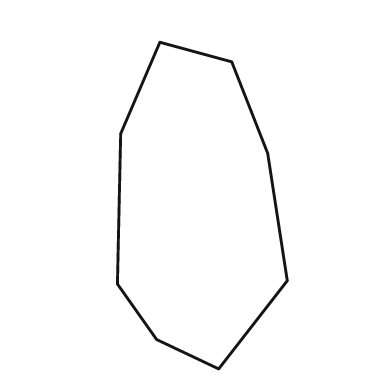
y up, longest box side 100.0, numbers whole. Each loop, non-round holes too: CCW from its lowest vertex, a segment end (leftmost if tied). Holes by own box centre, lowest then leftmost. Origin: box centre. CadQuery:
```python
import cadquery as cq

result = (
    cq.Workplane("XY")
    .moveTo(5.0, -50.0)
    .lineTo(26.0, -23.0)
    .lineTo(20.0, 16.0)
    .lineTo(9.0, 44.0)
    .lineTo(-13.0, 50.0)
    .lineTo(-25.0, 22.0)
    .lineTo(-26.0, -24.0)
    .lineTo(-14.0, -41.0)
    .close()
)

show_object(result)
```